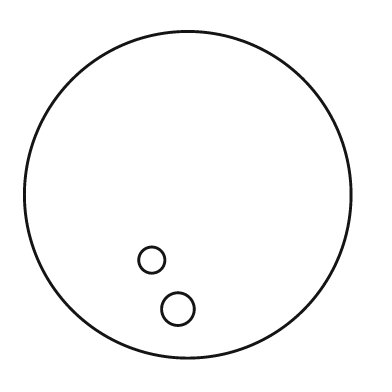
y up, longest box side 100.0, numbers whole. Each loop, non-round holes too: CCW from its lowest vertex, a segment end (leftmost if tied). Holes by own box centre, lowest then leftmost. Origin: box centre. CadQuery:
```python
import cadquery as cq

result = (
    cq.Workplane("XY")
    .moveTo(0.0, 0.0)
    .circle(50.0)
    .moveTo(-3.0, -35.0)
    .circle(5.0)
    .moveTo(-11.0, -20.0)
    .circle(4.0)
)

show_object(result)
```